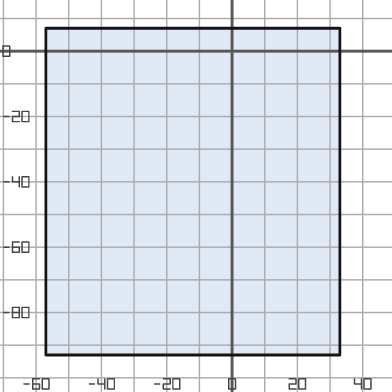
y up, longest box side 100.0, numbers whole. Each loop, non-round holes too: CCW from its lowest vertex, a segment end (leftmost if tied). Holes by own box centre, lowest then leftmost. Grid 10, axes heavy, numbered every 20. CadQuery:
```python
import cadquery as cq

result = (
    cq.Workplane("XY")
    .moveTo(-57.0, -93.0)
    .lineTo(33.0, -93.0)
    .lineTo(33.0, 7.0)
    .lineTo(-57.0, 7.0)
    .close()
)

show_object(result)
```